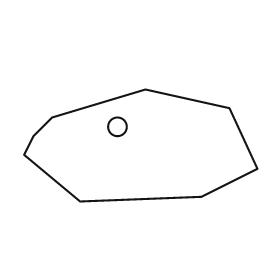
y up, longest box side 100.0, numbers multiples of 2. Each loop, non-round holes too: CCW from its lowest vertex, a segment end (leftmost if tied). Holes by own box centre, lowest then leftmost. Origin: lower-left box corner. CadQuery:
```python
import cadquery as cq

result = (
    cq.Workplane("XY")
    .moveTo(24.0, 0.0)
    .lineTo(76.0, 2.0)
    .lineTo(100.0, 14.0)
    .lineTo(88.0, 40.0)
    .lineTo(52.0, 48.0)
    .lineTo(12.0, 36.0)
    .lineTo(4.0, 28.0)
    .lineTo(0.0, 20.0)
    .close()
    .moveTo(40.0, 32.0)
    .circle(4.0)
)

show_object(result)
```